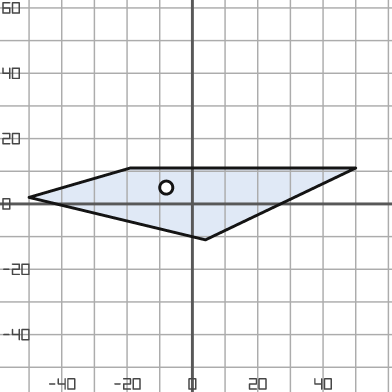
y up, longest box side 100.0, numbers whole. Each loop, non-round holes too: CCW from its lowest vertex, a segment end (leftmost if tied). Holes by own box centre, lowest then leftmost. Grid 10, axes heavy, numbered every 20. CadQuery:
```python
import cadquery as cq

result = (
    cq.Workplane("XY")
    .moveTo(4.0, -11.0)
    .lineTo(50.0, 11.0)
    .lineTo(-19.0, 11.0)
    .lineTo(-50.0, 2.0)
    .close()
    .moveTo(-8.0, 5.0)
    .circle(2.0)
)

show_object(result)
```